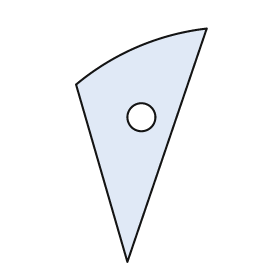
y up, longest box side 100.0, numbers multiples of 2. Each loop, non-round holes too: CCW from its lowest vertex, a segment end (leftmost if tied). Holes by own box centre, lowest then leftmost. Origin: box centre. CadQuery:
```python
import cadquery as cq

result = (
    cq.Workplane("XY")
    .moveTo(-6.0, -50.0)
    .lineTo(28.0, 50.0)
    .threePointArc((-2.0, 42.0), (-28.0, 26.0))
    .close()
    .moveTo(0.0, 12.0)
    .circle(6.0)
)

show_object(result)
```